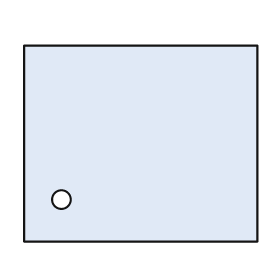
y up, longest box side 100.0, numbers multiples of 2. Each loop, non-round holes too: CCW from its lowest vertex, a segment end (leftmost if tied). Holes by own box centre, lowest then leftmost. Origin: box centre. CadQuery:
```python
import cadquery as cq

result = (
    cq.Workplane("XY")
    .moveTo(-50.0, -42.0)
    .lineTo(50.0, -42.0)
    .lineTo(50.0, 42.0)
    .lineTo(-50.0, 42.0)
    .close()
    .moveTo(-34.0, -24.0)
    .circle(4.0)
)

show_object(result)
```